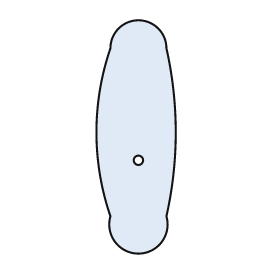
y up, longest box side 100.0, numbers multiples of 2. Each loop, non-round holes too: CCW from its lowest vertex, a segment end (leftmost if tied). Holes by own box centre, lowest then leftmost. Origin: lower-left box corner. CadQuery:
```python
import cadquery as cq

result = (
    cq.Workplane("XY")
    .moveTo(6.0, 16.0)
    .threePointArc((18.0, 0.0), (30.0, 16.0))
    .threePointArc((34.0, 52.0), (30.0, 88.0))
    .threePointArc((18.0, 100.0), (6.0, 88.0))
    .threePointArc((0.0, 52.0), (6.0, 16.0))
    .close()
    .moveTo(18.0, 40.0)
    .circle(2.0)
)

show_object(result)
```